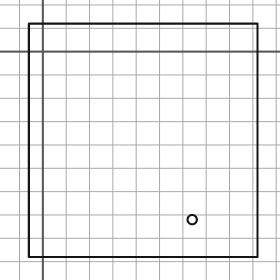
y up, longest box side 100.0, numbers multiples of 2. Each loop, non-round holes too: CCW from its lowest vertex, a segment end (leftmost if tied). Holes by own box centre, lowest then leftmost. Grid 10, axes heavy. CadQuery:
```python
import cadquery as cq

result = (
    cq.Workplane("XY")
    .moveTo(-6.0, -88.0)
    .lineTo(92.0, -88.0)
    .lineTo(92.0, 12.0)
    .lineTo(-6.0, 12.0)
    .close()
    .moveTo(64.0, -72.0)
    .circle(2.0)
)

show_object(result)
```